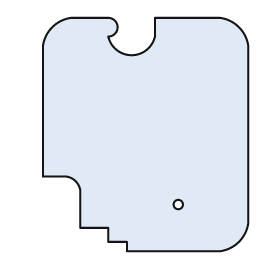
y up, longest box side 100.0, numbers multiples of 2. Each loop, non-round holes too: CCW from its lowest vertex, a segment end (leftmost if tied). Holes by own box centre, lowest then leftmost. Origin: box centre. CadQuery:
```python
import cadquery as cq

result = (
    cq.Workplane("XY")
    .moveTo(-8.0, -50.0)
    .lineTo(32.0, -50.0)
    .threePointArc((40.0, -46.0), (44.0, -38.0))
    .lineTo(44.0, 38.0)
    .threePointArc((40.0, 46.0), (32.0, 50.0))
    .lineTo(4.0, 50.0)
    .lineTo(4.0, 42.0)
    .threePointArc((-6.0, 34.0), (-16.0, 42.0))
    .threePointArc((-12.0, 46.0), (-16.0, 50.0))
    .lineTo(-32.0, 50.0)
    .threePointArc((-40.0, 46.0), (-44.0, 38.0))
    .lineTo(-44.0, -18.0)
    .lineTo(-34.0, -18.0)
    .threePointArc((-30.0, -20.0), (-28.0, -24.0))
    .lineTo(-28.0, -40.0)
    .lineTo(-16.0, -40.0)
    .lineTo(-16.0, -46.0)
    .lineTo(-8.0, -46.0)
    .close()
    .moveTo(14.0, -30.0)
    .circle(2.0)
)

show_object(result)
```